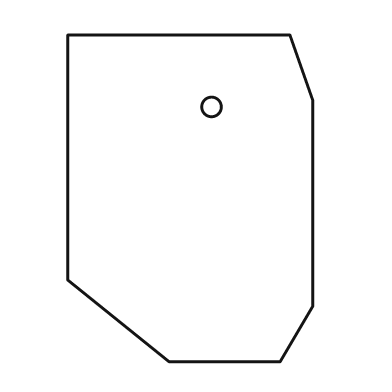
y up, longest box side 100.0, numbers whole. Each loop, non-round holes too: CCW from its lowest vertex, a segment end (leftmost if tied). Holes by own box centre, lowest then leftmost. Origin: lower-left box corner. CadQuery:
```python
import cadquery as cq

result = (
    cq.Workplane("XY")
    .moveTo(31.0, 0.0)
    .lineTo(65.0, 0.0)
    .lineTo(75.0, 17.0)
    .lineTo(75.0, 80.0)
    .lineTo(68.0, 100.0)
    .lineTo(0.0, 100.0)
    .lineTo(0.0, 25.0)
    .close()
    .moveTo(44.0, 78.0)
    .circle(3.0)
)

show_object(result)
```